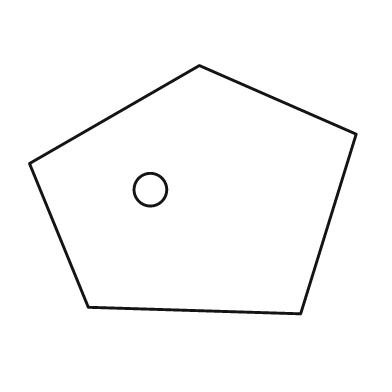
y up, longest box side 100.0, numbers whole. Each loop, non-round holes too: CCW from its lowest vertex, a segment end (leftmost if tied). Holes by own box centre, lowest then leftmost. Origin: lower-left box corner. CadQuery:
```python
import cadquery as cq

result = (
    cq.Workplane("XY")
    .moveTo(83.0, 0.0)
    .lineTo(100.0, 55.0)
    .lineTo(52.0, 76.0)
    .lineTo(0.0, 46.0)
    .lineTo(18.0, 2.0)
    .close()
    .moveTo(37.0, 38.0)
    .circle(5.0)
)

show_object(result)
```